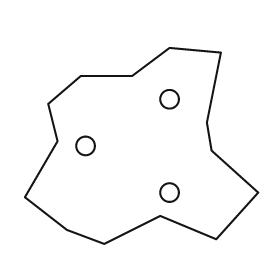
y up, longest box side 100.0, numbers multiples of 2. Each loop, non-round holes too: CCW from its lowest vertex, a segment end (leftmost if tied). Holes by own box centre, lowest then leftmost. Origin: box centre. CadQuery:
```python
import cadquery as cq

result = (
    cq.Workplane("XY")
    .moveTo(-16.0, -42.0)
    .lineTo(8.0, -30.0)
    .lineTo(32.0, -40.0)
    .lineTo(50.0, -20.0)
    .lineTo(30.0, -2.0)
    .lineTo(28.0, 10.0)
    .lineTo(34.0, 40.0)
    .lineTo(12.0, 42.0)
    .lineTo(-4.0, 30.0)
    .lineTo(-26.0, 30.0)
    .lineTo(-40.0, 18.0)
    .lineTo(-36.0, 2.0)
    .lineTo(-50.0, -22.0)
    .lineTo(-32.0, -36.0)
    .close()
    .moveTo(12.0, -20.0)
    .circle(4.0)
    .moveTo(-24.0, 0.0)
    .circle(4.0)
    .moveTo(12.0, 20.0)
    .circle(4.0)
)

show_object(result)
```